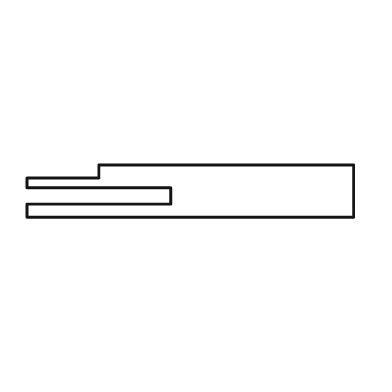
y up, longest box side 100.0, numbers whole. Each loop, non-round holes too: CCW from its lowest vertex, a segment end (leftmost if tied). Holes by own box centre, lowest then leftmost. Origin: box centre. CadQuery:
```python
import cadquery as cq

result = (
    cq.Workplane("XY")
    .moveTo(-50.0, -8.0)
    .lineTo(50.0, -8.0)
    .lineTo(50.0, 8.0)
    .lineTo(-28.0, 8.0)
    .lineTo(-28.0, 4.0)
    .lineTo(-50.0, 4.0)
    .lineTo(-50.0, 1.0)
    .lineTo(-6.0, 1.0)
    .lineTo(-6.0, -4.0)
    .lineTo(-50.0, -4.0)
    .close()
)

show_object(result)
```